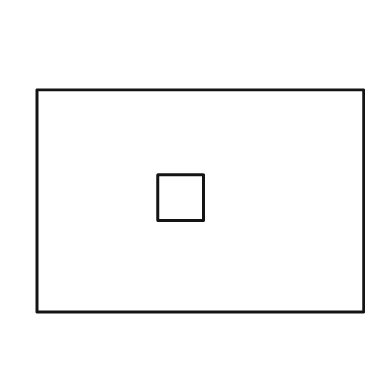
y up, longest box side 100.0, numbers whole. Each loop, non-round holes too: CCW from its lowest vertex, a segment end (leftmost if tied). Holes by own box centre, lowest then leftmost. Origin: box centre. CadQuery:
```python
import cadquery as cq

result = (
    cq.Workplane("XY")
    .moveTo(-50.0, -34.0)
    .lineTo(50.0, -34.0)
    .lineTo(50.0, 34.0)
    .lineTo(-50.0, 34.0)
    .close()
    .moveTo(-13.0, -6.0)
    .lineTo(1.0, -6.0)
    .lineTo(1.0, 8.0)
    .lineTo(-13.0, 8.0)
    .close()
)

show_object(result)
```